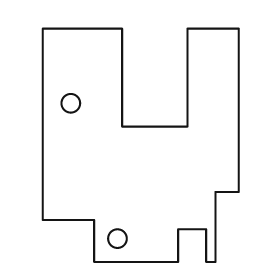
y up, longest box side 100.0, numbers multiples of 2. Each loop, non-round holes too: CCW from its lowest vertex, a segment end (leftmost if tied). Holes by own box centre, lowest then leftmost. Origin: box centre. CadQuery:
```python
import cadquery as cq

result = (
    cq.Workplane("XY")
    .moveTo(-20.0, -50.0)
    .lineTo(16.0, -50.0)
    .lineTo(16.0, -36.0)
    .lineTo(28.0, -36.0)
    .lineTo(28.0, -50.0)
    .lineTo(32.0, -50.0)
    .lineTo(32.0, -20.0)
    .lineTo(42.0, -20.0)
    .lineTo(42.0, 50.0)
    .lineTo(20.0, 50.0)
    .lineTo(20.0, 8.0)
    .lineTo(-8.0, 8.0)
    .lineTo(-8.0, 50.0)
    .lineTo(-42.0, 50.0)
    .lineTo(-42.0, -32.0)
    .lineTo(-20.0, -32.0)
    .close()
    .moveTo(-10.0, -40.0)
    .circle(4.0)
    .moveTo(-30.0, 18.0)
    .circle(4.0)
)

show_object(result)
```